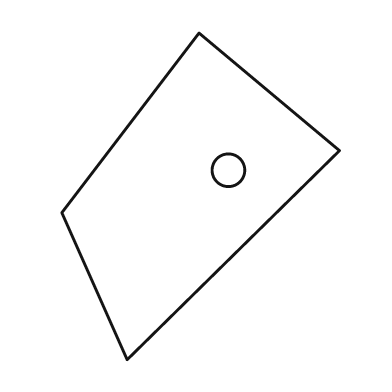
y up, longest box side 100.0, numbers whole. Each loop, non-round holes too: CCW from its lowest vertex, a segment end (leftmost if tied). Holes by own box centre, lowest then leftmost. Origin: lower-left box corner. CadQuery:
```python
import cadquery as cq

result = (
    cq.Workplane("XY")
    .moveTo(20.0, 0.0)
    .lineTo(85.0, 64.0)
    .lineTo(42.0, 100.0)
    .lineTo(0.0, 45.0)
    .close()
    .moveTo(51.0, 58.0)
    .circle(5.0)
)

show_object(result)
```